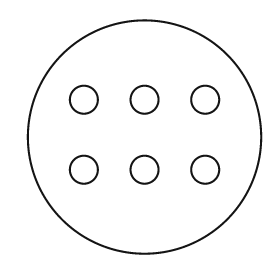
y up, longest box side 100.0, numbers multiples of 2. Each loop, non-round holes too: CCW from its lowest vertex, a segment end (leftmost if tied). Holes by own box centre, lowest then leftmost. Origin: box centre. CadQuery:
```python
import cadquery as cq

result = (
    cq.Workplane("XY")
    .moveTo(0.0, 0.0)
    .circle(50.0)
    .moveTo(-26.0, -14.0)
    .circle(6.0)
    .moveTo(0.0, -14.0)
    .circle(6.0)
    .moveTo(26.0, -14.0)
    .circle(6.0)
    .moveTo(-26.0, 16.0)
    .circle(6.0)
    .moveTo(0.0, 16.0)
    .circle(6.0)
    .moveTo(26.0, 16.0)
    .circle(6.0)
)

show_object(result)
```